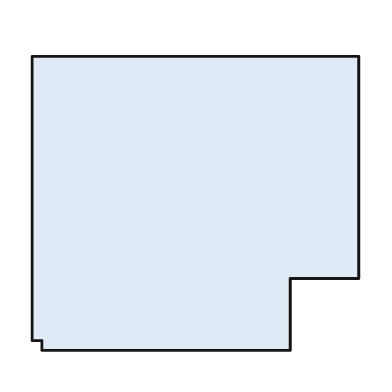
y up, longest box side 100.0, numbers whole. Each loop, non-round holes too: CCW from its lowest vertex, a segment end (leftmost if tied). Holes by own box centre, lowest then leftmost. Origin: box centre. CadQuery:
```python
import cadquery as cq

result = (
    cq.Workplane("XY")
    .moveTo(-47.0, -45.0)
    .lineTo(29.0, -45.0)
    .lineTo(29.0, -23.0)
    .lineTo(50.0, -23.0)
    .lineTo(50.0, 45.0)
    .lineTo(-50.0, 45.0)
    .lineTo(-50.0, -42.0)
    .lineTo(-47.0, -42.0)
    .close()
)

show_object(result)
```